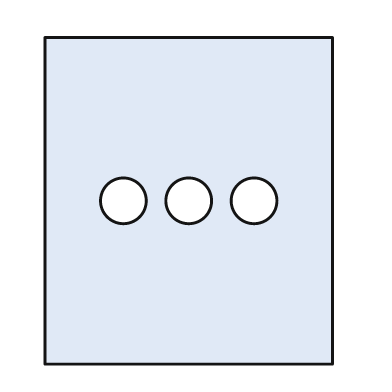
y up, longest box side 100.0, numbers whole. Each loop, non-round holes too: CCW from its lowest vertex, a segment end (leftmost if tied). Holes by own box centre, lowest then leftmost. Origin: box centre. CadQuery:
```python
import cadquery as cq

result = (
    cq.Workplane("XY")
    .moveTo(-44.0, -50.0)
    .lineTo(44.0, -50.0)
    .lineTo(44.0, 50.0)
    .lineTo(-44.0, 50.0)
    .close()
    .moveTo(-20.0, 0.0)
    .circle(7.0)
    .moveTo(0.0, 0.0)
    .circle(7.0)
    .moveTo(20.0, 0.0)
    .circle(7.0)
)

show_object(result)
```